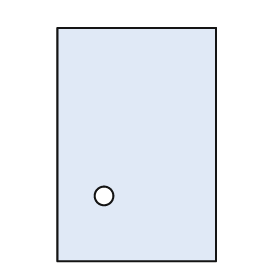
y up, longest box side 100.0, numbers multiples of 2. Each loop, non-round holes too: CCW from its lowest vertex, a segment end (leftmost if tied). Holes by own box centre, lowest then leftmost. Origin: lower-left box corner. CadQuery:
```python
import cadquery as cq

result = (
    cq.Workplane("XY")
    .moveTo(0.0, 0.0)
    .lineTo(68.0, 0.0)
    .lineTo(68.0, 100.0)
    .lineTo(0.0, 100.0)
    .close()
    .moveTo(20.0, 28.0)
    .circle(4.0)
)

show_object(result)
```